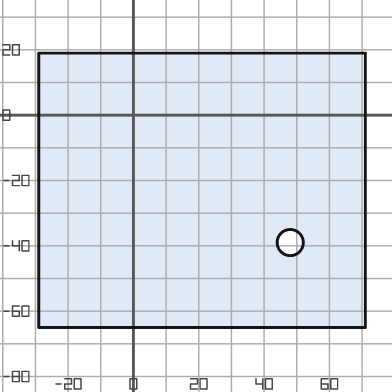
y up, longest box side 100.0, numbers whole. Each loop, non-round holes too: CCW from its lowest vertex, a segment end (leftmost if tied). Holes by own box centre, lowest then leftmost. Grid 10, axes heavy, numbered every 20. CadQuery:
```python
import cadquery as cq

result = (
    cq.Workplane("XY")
    .moveTo(-29.0, -65.0)
    .lineTo(71.0, -65.0)
    .lineTo(71.0, 19.0)
    .lineTo(-29.0, 19.0)
    .close()
    .moveTo(48.0, -39.0)
    .circle(4.0)
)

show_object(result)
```